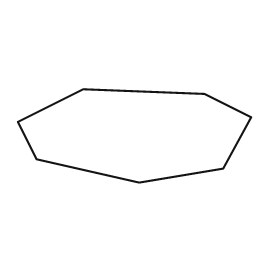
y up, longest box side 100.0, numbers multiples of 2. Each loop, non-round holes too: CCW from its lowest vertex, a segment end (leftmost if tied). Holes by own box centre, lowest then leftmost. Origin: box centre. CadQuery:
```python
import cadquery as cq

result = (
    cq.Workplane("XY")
    .moveTo(2.0, -20.0)
    .lineTo(38.0, -14.0)
    .lineTo(50.0, 8.0)
    .lineTo(30.0, 18.0)
    .lineTo(-22.0, 20.0)
    .lineTo(-50.0, 6.0)
    .lineTo(-42.0, -10.0)
    .close()
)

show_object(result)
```